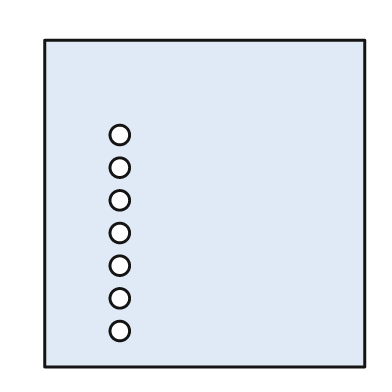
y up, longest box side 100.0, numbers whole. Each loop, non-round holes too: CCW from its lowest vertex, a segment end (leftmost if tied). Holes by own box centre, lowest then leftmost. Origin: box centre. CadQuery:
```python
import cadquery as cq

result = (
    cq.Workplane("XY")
    .moveTo(-49.0, -50.0)
    .lineTo(49.0, -50.0)
    .lineTo(49.0, 50.0)
    .lineTo(-49.0, 50.0)
    .close()
    .moveTo(-26.0, -39.0)
    .circle(3.0)
    .moveTo(-26.0, -29.0)
    .circle(3.0)
    .moveTo(-26.0, -19.0)
    .circle(3.0)
    .moveTo(-26.0, -9.0)
    .circle(3.0)
    .moveTo(-26.0, 1.0)
    .circle(3.0)
    .moveTo(-26.0, 11.0)
    .circle(3.0)
    .moveTo(-26.0, 21.0)
    .circle(3.0)
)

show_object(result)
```